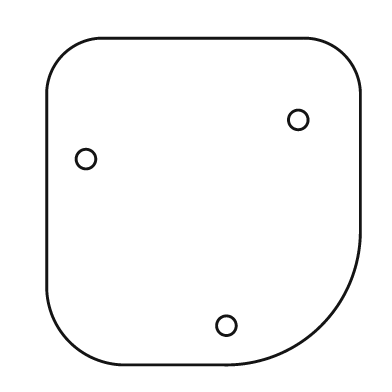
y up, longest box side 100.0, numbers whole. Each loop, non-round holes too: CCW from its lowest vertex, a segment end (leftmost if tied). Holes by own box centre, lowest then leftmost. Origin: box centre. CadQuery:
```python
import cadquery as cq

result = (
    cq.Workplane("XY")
    .moveTo(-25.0, -50.0)
    .lineTo(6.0, -50.0)
    .threePointArc((36.0, -38.0), (48.0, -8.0))
    .lineTo(48.0, 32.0)
    .threePointArc((43.0, 45.0), (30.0, 50.0))
    .lineTo(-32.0, 50.0)
    .threePointArc((-43.0, 45.0), (-48.0, 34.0))
    .lineTo(-48.0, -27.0)
    .threePointArc((-41.0, -43.0), (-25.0, -50.0))
    .close()
    .moveTo(7.0, -38.0)
    .circle(3.0)
    .moveTo(-36.0, 13.0)
    .circle(3.0)
    .moveTo(29.0, 25.0)
    .circle(3.0)
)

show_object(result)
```